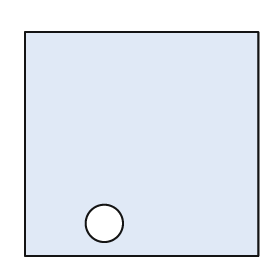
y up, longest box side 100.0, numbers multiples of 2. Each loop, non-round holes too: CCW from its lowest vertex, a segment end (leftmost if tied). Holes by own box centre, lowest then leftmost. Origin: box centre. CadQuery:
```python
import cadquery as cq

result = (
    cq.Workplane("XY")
    .moveTo(-50.0, -48.0)
    .lineTo(50.0, -48.0)
    .lineTo(50.0, 48.0)
    .lineTo(-50.0, 48.0)
    .close()
    .moveTo(-16.0, -34.0)
    .circle(8.0)
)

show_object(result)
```